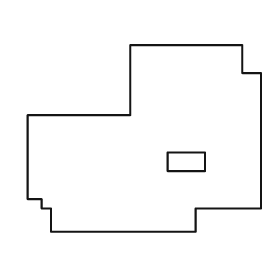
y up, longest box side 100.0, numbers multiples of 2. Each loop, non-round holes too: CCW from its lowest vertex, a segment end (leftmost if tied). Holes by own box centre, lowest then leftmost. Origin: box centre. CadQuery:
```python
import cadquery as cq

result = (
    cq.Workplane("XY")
    .moveTo(-40.0, -40.0)
    .lineTo(22.0, -40.0)
    .lineTo(22.0, -30.0)
    .lineTo(50.0, -30.0)
    .lineTo(50.0, 28.0)
    .lineTo(42.0, 28.0)
    .lineTo(42.0, 40.0)
    .lineTo(-6.0, 40.0)
    .lineTo(-6.0, 10.0)
    .lineTo(-50.0, 10.0)
    .lineTo(-50.0, -26.0)
    .lineTo(-44.0, -26.0)
    .lineTo(-44.0, -30.0)
    .lineTo(-40.0, -30.0)
    .close()
    .moveTo(10.0, -14.0)
    .lineTo(26.0, -14.0)
    .lineTo(26.0, -6.0)
    .lineTo(10.0, -6.0)
    .close()
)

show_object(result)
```